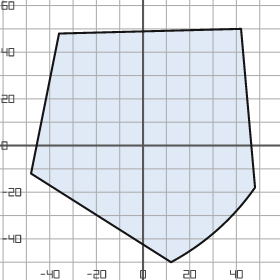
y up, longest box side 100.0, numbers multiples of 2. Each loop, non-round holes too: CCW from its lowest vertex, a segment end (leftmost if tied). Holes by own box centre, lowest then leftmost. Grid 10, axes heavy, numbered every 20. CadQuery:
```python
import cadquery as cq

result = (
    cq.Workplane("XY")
    .moveTo(12.0, -50.0)
    .threePointArc((32.0, -36.0), (48.0, -18.0))
    .lineTo(42.0, 50.0)
    .lineTo(-36.0, 48.0)
    .lineTo(-48.0, -12.0)
    .close()
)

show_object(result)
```